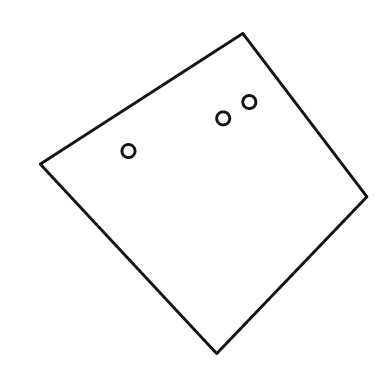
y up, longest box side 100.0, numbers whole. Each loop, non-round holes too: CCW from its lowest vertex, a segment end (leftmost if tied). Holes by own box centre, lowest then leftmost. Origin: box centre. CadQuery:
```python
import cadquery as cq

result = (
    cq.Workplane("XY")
    .moveTo(4.0, -49.0)
    .lineTo(50.0, -1.0)
    .lineTo(12.0, 49.0)
    .lineTo(-50.0, 9.0)
    .close()
    .moveTo(-23.0, 13.0)
    .circle(2.0)
    .moveTo(6.0, 23.0)
    .circle(2.0)
    .moveTo(14.0, 28.0)
    .circle(2.0)
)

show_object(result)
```